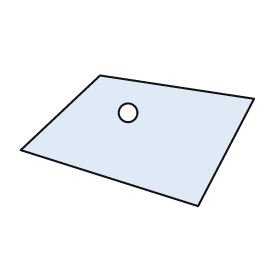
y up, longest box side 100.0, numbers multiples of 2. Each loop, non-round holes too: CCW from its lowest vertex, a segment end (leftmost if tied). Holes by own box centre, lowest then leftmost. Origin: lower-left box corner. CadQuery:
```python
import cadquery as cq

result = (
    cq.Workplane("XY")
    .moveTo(76.0, 0.0)
    .lineTo(100.0, 46.0)
    .lineTo(34.0, 56.0)
    .lineTo(0.0, 24.0)
    .close()
    .moveTo(46.0, 40.0)
    .circle(4.0)
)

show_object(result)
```